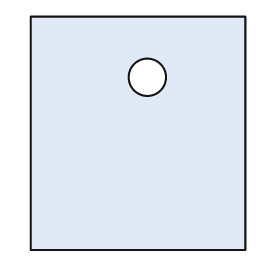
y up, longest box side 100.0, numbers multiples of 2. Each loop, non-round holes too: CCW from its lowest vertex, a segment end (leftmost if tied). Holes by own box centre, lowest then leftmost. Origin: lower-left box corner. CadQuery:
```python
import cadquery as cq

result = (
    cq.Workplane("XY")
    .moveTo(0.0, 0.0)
    .lineTo(92.0, 0.0)
    .lineTo(92.0, 100.0)
    .lineTo(0.0, 100.0)
    .close()
    .moveTo(50.0, 74.0)
    .circle(8.0)
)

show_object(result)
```